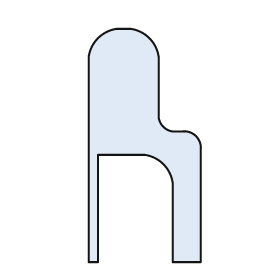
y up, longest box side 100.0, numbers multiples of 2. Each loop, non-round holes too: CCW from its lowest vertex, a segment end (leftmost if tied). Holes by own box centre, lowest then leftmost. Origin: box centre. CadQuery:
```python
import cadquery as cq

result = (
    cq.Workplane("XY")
    .moveTo(-24.0, -50.0)
    .lineTo(-20.0, -50.0)
    .lineTo(-20.0, -4.0)
    .lineTo(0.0, -4.0)
    .threePointArc((8.0, -8.0), (12.0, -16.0))
    .lineTo(12.0, -50.0)
    .lineTo(24.0, -50.0)
    .lineTo(24.0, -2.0)
    .threePointArc((22.0, 4.0), (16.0, 6.0))
    .lineTo(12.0, 6.0)
    .threePointArc((8.0, 8.0), (6.0, 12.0))
    .lineTo(6.0, 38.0)
    .threePointArc((2.0, 46.0), (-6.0, 50.0))
    .lineTo(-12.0, 50.0)
    .threePointArc((-20.0, 46.0), (-24.0, 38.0))
    .close()
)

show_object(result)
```